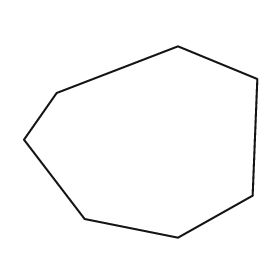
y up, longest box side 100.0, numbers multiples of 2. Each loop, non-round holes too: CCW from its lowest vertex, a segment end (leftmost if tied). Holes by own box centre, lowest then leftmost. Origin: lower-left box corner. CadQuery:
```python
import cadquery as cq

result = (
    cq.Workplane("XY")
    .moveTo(66.0, 0.0)
    .lineTo(98.0, 18.0)
    .lineTo(100.0, 68.0)
    .lineTo(66.0, 82.0)
    .lineTo(14.0, 62.0)
    .lineTo(0.0, 42.0)
    .lineTo(26.0, 8.0)
    .close()
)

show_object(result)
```